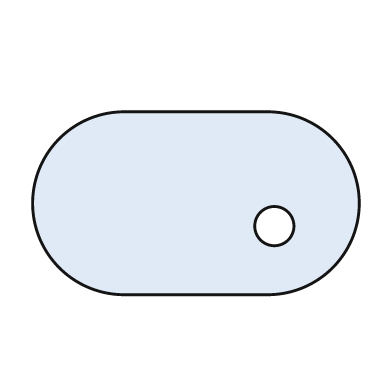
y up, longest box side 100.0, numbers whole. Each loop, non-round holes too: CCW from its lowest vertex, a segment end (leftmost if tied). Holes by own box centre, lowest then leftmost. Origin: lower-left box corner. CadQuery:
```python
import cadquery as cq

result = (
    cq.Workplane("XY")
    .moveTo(28.0, 0.0)
    .lineTo(72.0, 0.0)
    .threePointArc((100.0, 28.0), (72.0, 56.0))
    .lineTo(28.0, 56.0)
    .threePointArc((0.0, 28.0), (28.0, 0.0))
    .close()
    .moveTo(74.0, 21.0)
    .circle(6.0)
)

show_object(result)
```